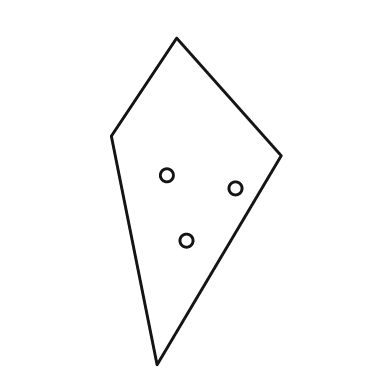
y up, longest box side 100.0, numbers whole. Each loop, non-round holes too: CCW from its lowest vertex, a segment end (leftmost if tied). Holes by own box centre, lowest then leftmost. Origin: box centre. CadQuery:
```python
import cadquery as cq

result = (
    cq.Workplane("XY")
    .moveTo(-12.0, -50.0)
    .lineTo(26.0, 14.0)
    .lineTo(-6.0, 50.0)
    .lineTo(-26.0, 20.0)
    .close()
    .moveTo(-3.0, -12.0)
    .circle(2.0)
    .moveTo(12.0, 4.0)
    .circle(2.0)
    .moveTo(-9.0, 8.0)
    .circle(2.0)
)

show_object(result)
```